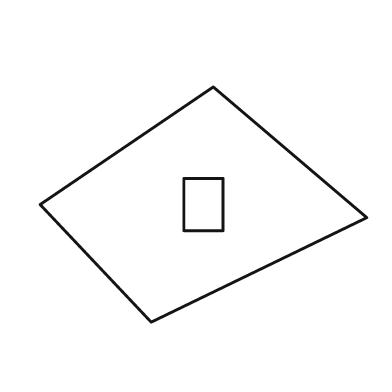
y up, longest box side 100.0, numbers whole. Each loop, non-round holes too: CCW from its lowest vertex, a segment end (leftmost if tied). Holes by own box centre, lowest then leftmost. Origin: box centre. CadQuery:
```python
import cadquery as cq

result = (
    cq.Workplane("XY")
    .moveTo(-16.0, -36.0)
    .lineTo(50.0, -4.0)
    .lineTo(3.0, 36.0)
    .lineTo(-50.0, 0.0)
    .close()
    .moveTo(-6.0, -8.0)
    .lineTo(6.0, -8.0)
    .lineTo(6.0, 8.0)
    .lineTo(-6.0, 8.0)
    .close()
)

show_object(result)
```